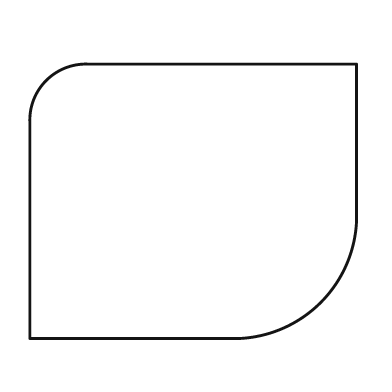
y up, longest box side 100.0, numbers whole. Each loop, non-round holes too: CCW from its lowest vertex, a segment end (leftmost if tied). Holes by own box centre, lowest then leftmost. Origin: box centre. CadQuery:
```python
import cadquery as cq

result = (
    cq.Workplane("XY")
    .moveTo(-50.0, -42.0)
    .lineTo(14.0, -42.0)
    .threePointArc((39.0, -31.0), (50.0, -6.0))
    .lineTo(50.0, 42.0)
    .lineTo(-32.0, 42.0)
    .threePointArc((-45.0, 37.0), (-50.0, 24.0))
    .close()
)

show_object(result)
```